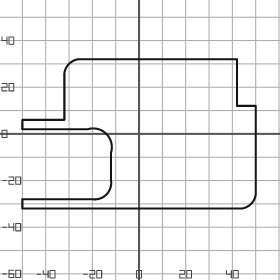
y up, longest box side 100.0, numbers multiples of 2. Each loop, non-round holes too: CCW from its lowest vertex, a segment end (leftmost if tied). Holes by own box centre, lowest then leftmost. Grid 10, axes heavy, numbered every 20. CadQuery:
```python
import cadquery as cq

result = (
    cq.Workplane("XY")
    .moveTo(-50.0, -32.0)
    .lineTo(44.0, -32.0)
    .threePointArc((48.0, -30.0), (50.0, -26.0))
    .lineTo(50.0, 12.0)
    .lineTo(42.0, 12.0)
    .lineTo(42.0, 32.0)
    .lineTo(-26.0, 32.0)
    .threePointArc((-30.0, 30.0), (-32.0, 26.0))
    .lineTo(-32.0, 6.0)
    .lineTo(-50.0, 6.0)
    .lineTo(-50.0, 2.0)
    .lineTo(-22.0, 2.0)
    .threePointArc((-14.0, 0.0), (-12.0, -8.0))
    .lineTo(-12.0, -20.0)
    .threePointArc((-14.0, -26.0), (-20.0, -28.0))
    .lineTo(-50.0, -28.0)
    .close()
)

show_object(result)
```